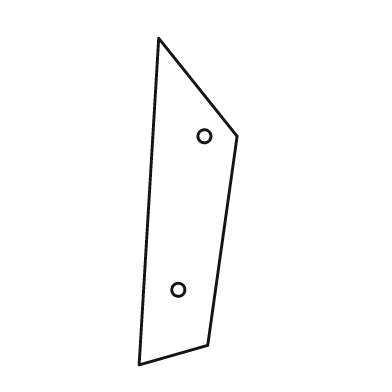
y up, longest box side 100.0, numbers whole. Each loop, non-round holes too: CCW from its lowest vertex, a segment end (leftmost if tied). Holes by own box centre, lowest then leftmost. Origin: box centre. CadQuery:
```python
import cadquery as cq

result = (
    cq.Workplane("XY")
    .moveTo(-15.0, -50.0)
    .lineTo(6.0, -44.0)
    .lineTo(15.0, 20.0)
    .lineTo(-9.0, 50.0)
    .close()
    .moveTo(-3.0, -27.0)
    .circle(2.0)
    .moveTo(5.0, 20.0)
    .circle(2.0)
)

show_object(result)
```